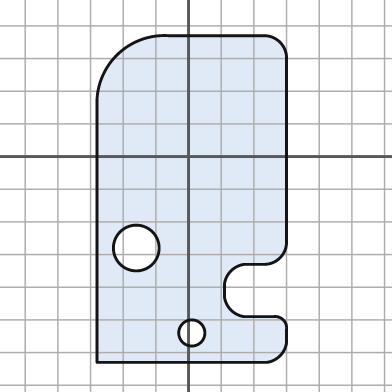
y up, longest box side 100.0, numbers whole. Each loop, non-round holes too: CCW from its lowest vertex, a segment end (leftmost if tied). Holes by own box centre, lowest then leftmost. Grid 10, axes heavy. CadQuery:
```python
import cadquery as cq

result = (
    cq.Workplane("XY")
    .moveTo(-28.0, -63.0)
    .lineTo(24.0, -63.0)
    .threePointArc((28.0, -61.0), (30.0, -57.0))
    .lineTo(30.0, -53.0)
    .threePointArc((29.0, -50.0), (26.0, -49.0))
    .lineTo(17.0, -49.0)
    .threePointArc((13.0, -47.0), (11.0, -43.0))
    .lineTo(11.0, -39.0)
    .threePointArc((13.0, -35.0), (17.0, -33.0))
    .lineTo(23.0, -33.0)
    .threePointArc((28.0, -31.0), (30.0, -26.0))
    .lineTo(30.0, 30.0)
    .threePointArc((28.0, 35.0), (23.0, 37.0))
    .lineTo(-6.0, 37.0)
    .threePointArc((-22.0, 31.0), (-28.0, 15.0))
    .close()
    .moveTo(1.0, -54.0)
    .circle(4.0)
    .moveTo(-16.0, -28.0)
    .circle(7.0)
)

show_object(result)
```